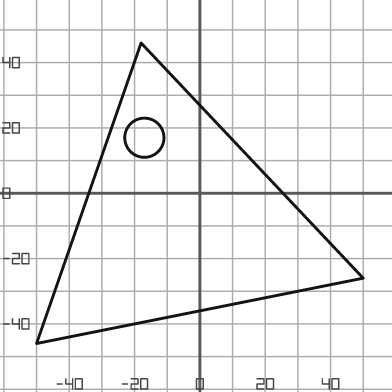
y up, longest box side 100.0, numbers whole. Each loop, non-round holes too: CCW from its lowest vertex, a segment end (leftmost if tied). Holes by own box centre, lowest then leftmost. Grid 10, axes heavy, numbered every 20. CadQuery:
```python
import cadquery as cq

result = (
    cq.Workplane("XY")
    .moveTo(-50.0, -46.0)
    .lineTo(50.0, -26.0)
    .lineTo(-18.0, 46.0)
    .close()
    .moveTo(-17.0, 17.0)
    .circle(6.0)
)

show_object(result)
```